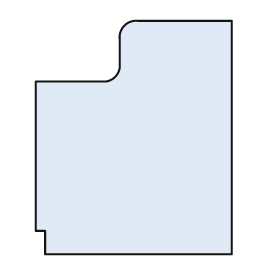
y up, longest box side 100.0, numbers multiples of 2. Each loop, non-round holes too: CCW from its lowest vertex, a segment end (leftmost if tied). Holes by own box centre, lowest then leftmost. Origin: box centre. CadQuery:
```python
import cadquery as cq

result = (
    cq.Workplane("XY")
    .moveTo(-38.0, -50.0)
    .lineTo(42.0, -50.0)
    .lineTo(42.0, 50.0)
    .lineTo(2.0, 50.0)
    .threePointArc((-4.0, 48.0), (-6.0, 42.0))
    .lineTo(-6.0, 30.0)
    .threePointArc((-8.0, 26.0), (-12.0, 24.0))
    .lineTo(-42.0, 24.0)
    .lineTo(-42.0, -40.0)
    .lineTo(-38.0, -40.0)
    .close()
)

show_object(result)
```